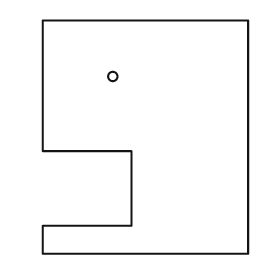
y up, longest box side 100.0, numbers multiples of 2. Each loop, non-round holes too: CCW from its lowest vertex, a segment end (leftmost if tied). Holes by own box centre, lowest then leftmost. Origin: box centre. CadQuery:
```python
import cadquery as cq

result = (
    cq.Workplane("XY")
    .moveTo(-44.0, -50.0)
    .lineTo(44.0, -50.0)
    .lineTo(44.0, 50.0)
    .lineTo(-44.0, 50.0)
    .lineTo(-44.0, -6.0)
    .lineTo(-6.0, -6.0)
    .lineTo(-6.0, -38.0)
    .lineTo(-44.0, -38.0)
    .close()
    .moveTo(-14.0, 26.0)
    .circle(2.0)
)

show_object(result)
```